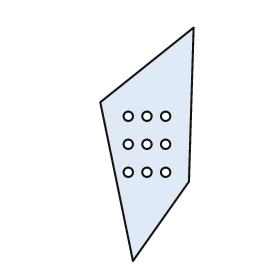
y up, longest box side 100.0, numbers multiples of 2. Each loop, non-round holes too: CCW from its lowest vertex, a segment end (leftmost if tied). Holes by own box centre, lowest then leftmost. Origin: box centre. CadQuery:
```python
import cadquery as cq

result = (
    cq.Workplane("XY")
    .moveTo(-6.0, -50.0)
    .lineTo(18.0, -16.0)
    .lineTo(20.0, 50.0)
    .lineTo(-20.0, 18.0)
    .close()
    .moveTo(-8.0, -12.0)
    .circle(2.0)
    .moveTo(0.0, -12.0)
    .circle(2.0)
    .moveTo(8.0, -12.0)
    .circle(2.0)
    .moveTo(-8.0, 0.0)
    .circle(2.0)
    .moveTo(0.0, 0.0)
    .circle(2.0)
    .moveTo(8.0, 0.0)
    .circle(2.0)
    .moveTo(-8.0, 12.0)
    .circle(2.0)
    .moveTo(0.0, 12.0)
    .circle(2.0)
    .moveTo(8.0, 12.0)
    .circle(2.0)
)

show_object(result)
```